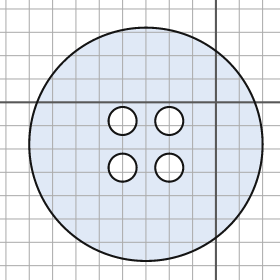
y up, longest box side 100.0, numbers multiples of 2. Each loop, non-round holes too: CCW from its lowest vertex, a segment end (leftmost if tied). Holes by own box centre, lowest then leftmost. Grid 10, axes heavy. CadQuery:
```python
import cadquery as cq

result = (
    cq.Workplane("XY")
    .moveTo(-30.0, -18.0)
    .circle(50.0)
    .moveTo(-40.0, -28.0)
    .circle(6.0)
    .moveTo(-20.0, -28.0)
    .circle(6.0)
    .moveTo(-40.0, -8.0)
    .circle(6.0)
    .moveTo(-20.0, -8.0)
    .circle(6.0)
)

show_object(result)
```